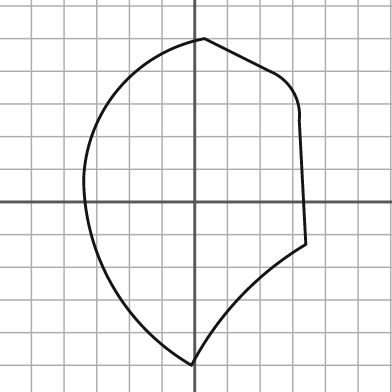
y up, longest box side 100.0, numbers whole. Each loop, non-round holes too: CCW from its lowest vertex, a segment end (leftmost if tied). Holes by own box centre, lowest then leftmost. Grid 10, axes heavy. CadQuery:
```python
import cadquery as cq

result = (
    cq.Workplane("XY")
    .moveTo(-1.0, -50.0)
    .threePointArc((14.0, -29.0), (34.0, -13.0))
    .lineTo(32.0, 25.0)
    .threePointArc((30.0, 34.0), (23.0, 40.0))
    .lineTo(3.0, 50.0)
    .threePointArc((-23.0, 35.0), (-34.0, 7.0))
    .threePointArc((-25.0, -26.0), (-1.0, -50.0))
    .close()
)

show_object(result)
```